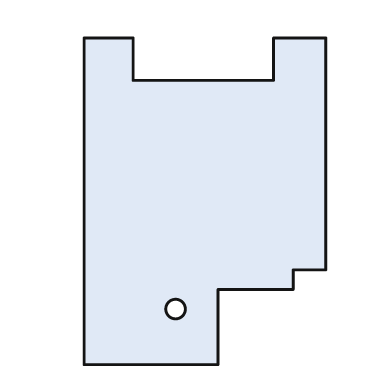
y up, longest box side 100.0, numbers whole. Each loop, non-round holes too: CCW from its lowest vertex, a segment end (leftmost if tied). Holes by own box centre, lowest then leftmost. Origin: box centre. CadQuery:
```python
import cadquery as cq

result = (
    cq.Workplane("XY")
    .moveTo(-37.0, -50.0)
    .lineTo(4.0, -50.0)
    .lineTo(4.0, -27.0)
    .lineTo(27.0, -27.0)
    .lineTo(27.0, -21.0)
    .lineTo(37.0, -21.0)
    .lineTo(37.0, 50.0)
    .lineTo(21.0, 50.0)
    .lineTo(21.0, 37.0)
    .lineTo(-22.0, 37.0)
    .lineTo(-22.0, 50.0)
    .lineTo(-37.0, 50.0)
    .close()
    .moveTo(-9.0, -33.0)
    .circle(3.0)
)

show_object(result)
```